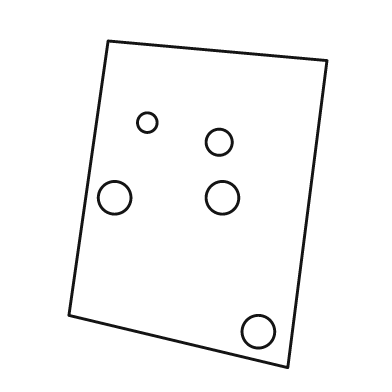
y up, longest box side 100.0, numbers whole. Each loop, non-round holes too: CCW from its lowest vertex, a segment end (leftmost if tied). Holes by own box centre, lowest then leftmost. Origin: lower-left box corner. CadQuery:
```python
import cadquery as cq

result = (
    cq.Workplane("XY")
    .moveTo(67.0, 0.0)
    .lineTo(79.0, 94.0)
    .lineTo(12.0, 100.0)
    .lineTo(0.0, 16.0)
    .close()
    .moveTo(58.0, 11.0)
    .circle(5.0)
    .moveTo(14.0, 52.0)
    .circle(5.0)
    .moveTo(47.0, 52.0)
    .circle(5.0)
    .moveTo(46.0, 69.0)
    .circle(4.0)
    .moveTo(24.0, 75.0)
    .circle(3.0)
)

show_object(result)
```